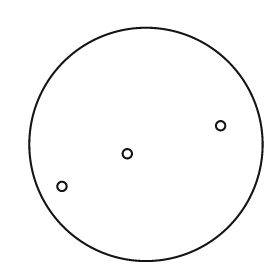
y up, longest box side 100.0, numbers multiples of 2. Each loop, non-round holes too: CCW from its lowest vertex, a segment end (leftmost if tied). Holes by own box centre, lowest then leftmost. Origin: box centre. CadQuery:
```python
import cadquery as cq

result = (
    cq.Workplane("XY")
    .moveTo(0.0, 0.0)
    .circle(50.0)
    .moveTo(-36.0, -18.0)
    .circle(2.0)
    .moveTo(-8.0, -4.0)
    .circle(2.0)
    .moveTo(32.0, 8.0)
    .circle(2.0)
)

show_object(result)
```